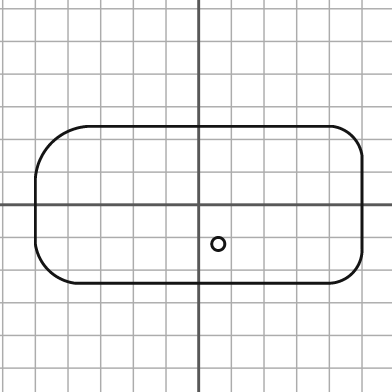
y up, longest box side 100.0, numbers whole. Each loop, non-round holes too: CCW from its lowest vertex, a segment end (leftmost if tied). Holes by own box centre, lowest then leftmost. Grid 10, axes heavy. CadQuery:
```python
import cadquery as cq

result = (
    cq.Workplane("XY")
    .moveTo(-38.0, -24.0)
    .lineTo(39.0, -24.0)
    .threePointArc((47.0, -21.0), (50.0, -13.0))
    .lineTo(50.0, 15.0)
    .threePointArc((47.0, 21.0), (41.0, 24.0))
    .lineTo(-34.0, 24.0)
    .threePointArc((-45.0, 19.0), (-50.0, 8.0))
    .lineTo(-50.0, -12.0)
    .threePointArc((-46.0, -20.0), (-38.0, -24.0))
    .close()
    .moveTo(6.0, -12.0)
    .circle(2.0)
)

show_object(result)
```